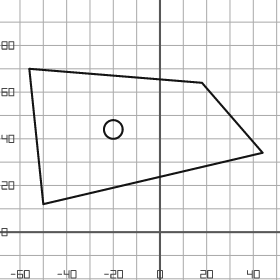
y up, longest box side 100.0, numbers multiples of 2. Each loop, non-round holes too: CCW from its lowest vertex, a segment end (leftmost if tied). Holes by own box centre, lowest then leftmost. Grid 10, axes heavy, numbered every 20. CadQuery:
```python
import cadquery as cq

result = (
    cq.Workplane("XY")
    .moveTo(-50.0, 12.0)
    .lineTo(44.0, 34.0)
    .lineTo(18.0, 64.0)
    .lineTo(-56.0, 70.0)
    .close()
    .moveTo(-20.0, 44.0)
    .circle(4.0)
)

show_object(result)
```